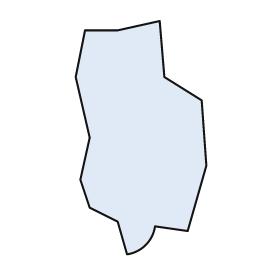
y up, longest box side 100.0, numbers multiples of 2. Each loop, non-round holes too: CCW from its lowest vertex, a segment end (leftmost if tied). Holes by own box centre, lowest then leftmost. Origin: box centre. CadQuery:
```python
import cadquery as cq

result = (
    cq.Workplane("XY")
    .moveTo(-6.0, -50.0)
    .threePointArc((2.0, -46.0), (6.0, -38.0))
    .lineTo(20.0, -40.0)
    .lineTo(28.0, -12.0)
    .lineTo(26.0, 16.0)
    .lineTo(10.0, 26.0)
    .lineTo(8.0, 50.0)
    .lineTo(-10.0, 46.0)
    .lineTo(-24.0, 46.0)
    .lineTo(-28.0, 26.0)
    .lineTo(-22.0, 0.0)
    .lineTo(-26.0, -18.0)
    .lineTo(-22.0, -30.0)
    .lineTo(-10.0, -36.0)
    .close()
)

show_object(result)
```